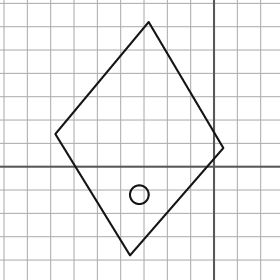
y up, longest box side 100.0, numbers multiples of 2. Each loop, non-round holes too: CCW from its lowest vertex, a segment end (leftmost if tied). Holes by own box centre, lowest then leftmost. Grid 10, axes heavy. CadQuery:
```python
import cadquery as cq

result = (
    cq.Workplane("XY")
    .moveTo(-36.0, -38.0)
    .lineTo(4.0, 8.0)
    .lineTo(-28.0, 62.0)
    .lineTo(-68.0, 14.0)
    .close()
    .moveTo(-32.0, -12.0)
    .circle(4.0)
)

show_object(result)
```